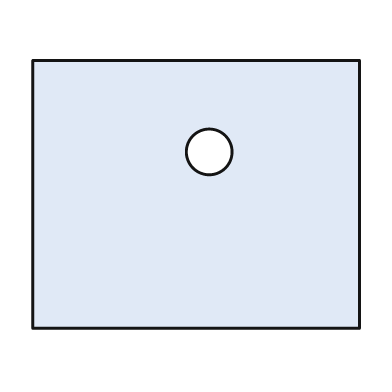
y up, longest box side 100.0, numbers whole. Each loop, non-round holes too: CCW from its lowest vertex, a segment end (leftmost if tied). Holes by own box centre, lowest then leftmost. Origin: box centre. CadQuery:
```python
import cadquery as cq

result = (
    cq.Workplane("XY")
    .moveTo(-50.0, -41.0)
    .lineTo(50.0, -41.0)
    .lineTo(50.0, 41.0)
    .lineTo(-50.0, 41.0)
    .close()
    .moveTo(4.0, 13.0)
    .circle(7.0)
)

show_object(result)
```